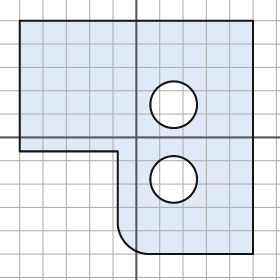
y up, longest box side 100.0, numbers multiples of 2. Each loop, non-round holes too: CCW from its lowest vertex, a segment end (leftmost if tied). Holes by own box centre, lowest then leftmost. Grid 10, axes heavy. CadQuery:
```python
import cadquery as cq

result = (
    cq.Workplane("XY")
    .moveTo(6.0, -50.0)
    .lineTo(50.0, -50.0)
    .lineTo(50.0, 50.0)
    .lineTo(-50.0, 50.0)
    .lineTo(-50.0, -6.0)
    .lineTo(-8.0, -6.0)
    .lineTo(-8.0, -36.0)
    .threePointArc((-4.0, -46.0), (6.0, -50.0))
    .close()
    .moveTo(16.0, -18.0)
    .circle(10.0)
    .moveTo(16.0, 14.0)
    .circle(10.0)
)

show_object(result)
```